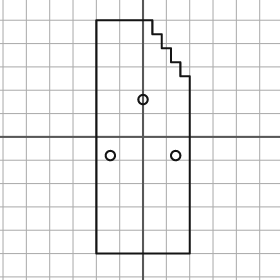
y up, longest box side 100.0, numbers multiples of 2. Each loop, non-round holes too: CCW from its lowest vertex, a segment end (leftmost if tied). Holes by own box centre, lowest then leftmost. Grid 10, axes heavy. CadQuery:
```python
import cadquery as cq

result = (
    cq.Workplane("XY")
    .moveTo(-20.0, -50.0)
    .lineTo(20.0, -50.0)
    .lineTo(20.0, 26.0)
    .lineTo(16.0, 26.0)
    .lineTo(16.0, 32.0)
    .lineTo(12.0, 32.0)
    .lineTo(12.0, 38.0)
    .lineTo(8.0, 38.0)
    .lineTo(8.0, 44.0)
    .lineTo(4.0, 44.0)
    .lineTo(4.0, 50.0)
    .lineTo(-20.0, 50.0)
    .close()
    .moveTo(-14.0, -8.0)
    .circle(2.0)
    .moveTo(14.0, -8.0)
    .circle(2.0)
    .moveTo(0.0, 16.0)
    .circle(2.0)
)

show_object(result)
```